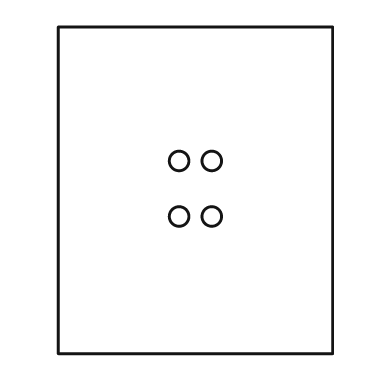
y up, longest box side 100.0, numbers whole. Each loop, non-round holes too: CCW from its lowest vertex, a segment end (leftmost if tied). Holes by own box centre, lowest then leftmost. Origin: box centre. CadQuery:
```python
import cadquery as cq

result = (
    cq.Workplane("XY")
    .moveTo(-42.0, -50.0)
    .lineTo(42.0, -50.0)
    .lineTo(42.0, 50.0)
    .lineTo(-42.0, 50.0)
    .close()
    .moveTo(-5.0, -8.0)
    .circle(3.0)
    .moveTo(5.0, -8.0)
    .circle(3.0)
    .moveTo(-5.0, 9.0)
    .circle(3.0)
    .moveTo(5.0, 9.0)
    .circle(3.0)
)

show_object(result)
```